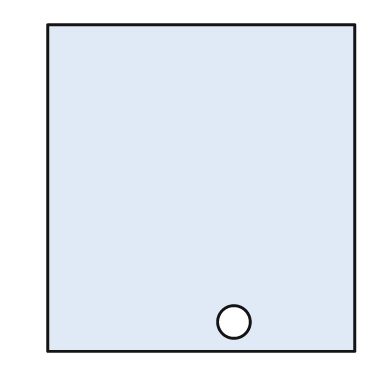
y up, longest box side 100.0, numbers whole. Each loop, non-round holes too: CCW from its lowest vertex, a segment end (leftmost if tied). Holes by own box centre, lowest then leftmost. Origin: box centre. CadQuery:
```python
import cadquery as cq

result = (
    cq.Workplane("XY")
    .moveTo(-47.0, -50.0)
    .lineTo(47.0, -50.0)
    .lineTo(47.0, 50.0)
    .lineTo(-47.0, 50.0)
    .close()
    .moveTo(10.0, -41.0)
    .circle(5.0)
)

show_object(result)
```